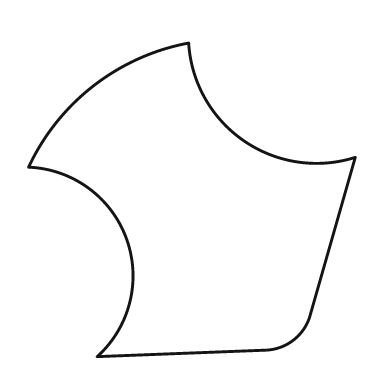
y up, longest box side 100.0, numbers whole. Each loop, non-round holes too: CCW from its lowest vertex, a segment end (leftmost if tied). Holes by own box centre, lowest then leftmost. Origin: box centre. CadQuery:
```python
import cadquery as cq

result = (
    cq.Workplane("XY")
    .moveTo(-29.0, -48.0)
    .lineTo(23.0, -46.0)
    .threePointArc((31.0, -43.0), (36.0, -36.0))
    .lineTo(50.0, 13.0)
    .threePointArc((16.0, 18.0), (-1.0, 48.0))
    .threePointArc((-30.0, 35.0), (-50.0, 10.0))
    .threePointArc((-20.0, -12.0), (-29.0, -48.0))
    .close()
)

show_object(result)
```